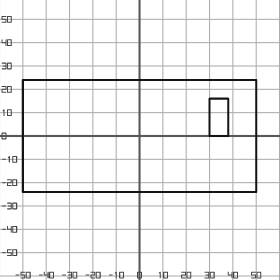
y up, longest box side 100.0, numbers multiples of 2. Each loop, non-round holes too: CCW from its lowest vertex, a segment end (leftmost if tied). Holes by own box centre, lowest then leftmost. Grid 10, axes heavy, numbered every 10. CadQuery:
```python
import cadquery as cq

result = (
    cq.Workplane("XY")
    .moveTo(-50.0, -24.0)
    .lineTo(50.0, -24.0)
    .lineTo(50.0, 24.0)
    .lineTo(-50.0, 24.0)
    .close()
    .moveTo(30.0, 0.0)
    .lineTo(38.0, 0.0)
    .lineTo(38.0, 16.0)
    .lineTo(30.0, 16.0)
    .close()
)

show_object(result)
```